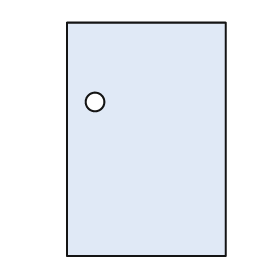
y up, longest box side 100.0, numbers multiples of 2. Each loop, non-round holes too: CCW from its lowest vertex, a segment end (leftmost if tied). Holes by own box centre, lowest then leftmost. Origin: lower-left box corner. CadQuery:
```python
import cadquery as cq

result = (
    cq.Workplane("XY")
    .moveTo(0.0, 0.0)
    .lineTo(68.0, 0.0)
    .lineTo(68.0, 100.0)
    .lineTo(0.0, 100.0)
    .close()
    .moveTo(12.0, 66.0)
    .circle(4.0)
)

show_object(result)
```